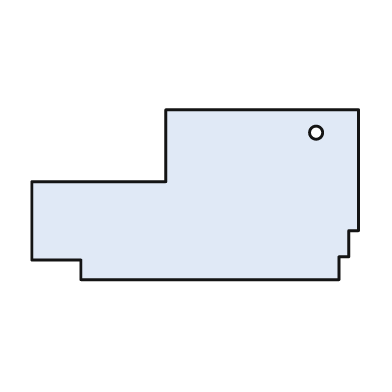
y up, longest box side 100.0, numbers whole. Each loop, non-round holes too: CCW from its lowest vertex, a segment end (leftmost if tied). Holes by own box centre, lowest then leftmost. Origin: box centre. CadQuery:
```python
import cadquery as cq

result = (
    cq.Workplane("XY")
    .moveTo(-35.0, -26.0)
    .lineTo(44.0, -26.0)
    .lineTo(44.0, -19.0)
    .lineTo(47.0, -19.0)
    .lineTo(47.0, -11.0)
    .lineTo(50.0, -11.0)
    .lineTo(50.0, 26.0)
    .lineTo(-9.0, 26.0)
    .lineTo(-9.0, 4.0)
    .lineTo(-50.0, 4.0)
    .lineTo(-50.0, -20.0)
    .lineTo(-35.0, -20.0)
    .close()
    .moveTo(37.0, 19.0)
    .circle(2.0)
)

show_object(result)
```